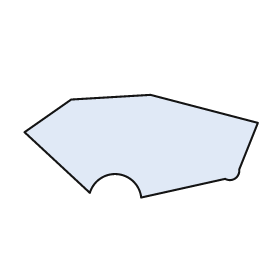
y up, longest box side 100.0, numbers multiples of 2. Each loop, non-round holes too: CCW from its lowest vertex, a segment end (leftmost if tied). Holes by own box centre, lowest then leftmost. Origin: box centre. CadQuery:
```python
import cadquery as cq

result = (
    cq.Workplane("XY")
    .moveTo(0.0, -22.0)
    .lineTo(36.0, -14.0)
    .threePointArc((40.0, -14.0), (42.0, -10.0))
    .lineTo(50.0, 10.0)
    .lineTo(4.0, 22.0)
    .lineTo(-30.0, 20.0)
    .lineTo(-50.0, 6.0)
    .lineTo(-22.0, -20.0)
    .threePointArc((-10.0, -12.0), (0.0, -22.0))
    .close()
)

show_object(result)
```